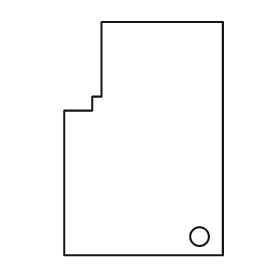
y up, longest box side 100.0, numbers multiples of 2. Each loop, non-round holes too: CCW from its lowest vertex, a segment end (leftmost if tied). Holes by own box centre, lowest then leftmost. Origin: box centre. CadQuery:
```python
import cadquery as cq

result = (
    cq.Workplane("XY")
    .moveTo(-34.0, -50.0)
    .lineTo(34.0, -50.0)
    .lineTo(34.0, 50.0)
    .lineTo(-18.0, 50.0)
    .lineTo(-18.0, 18.0)
    .lineTo(-22.0, 18.0)
    .lineTo(-22.0, 12.0)
    .lineTo(-34.0, 12.0)
    .close()
    .moveTo(24.0, -42.0)
    .circle(4.0)
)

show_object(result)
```